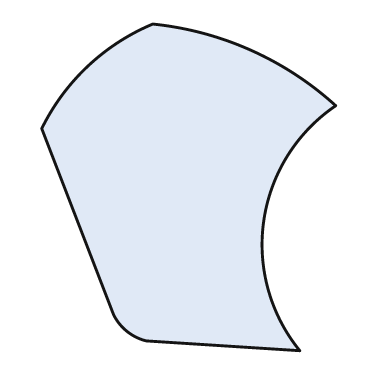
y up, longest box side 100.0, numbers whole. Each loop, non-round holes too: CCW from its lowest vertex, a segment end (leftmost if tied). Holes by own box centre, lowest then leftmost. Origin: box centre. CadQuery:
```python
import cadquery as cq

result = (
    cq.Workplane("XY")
    .moveTo(34.0, -50.0)
    .threePointArc((23.0, -10.0), (45.0, 25.0))
    .threePointArc((19.0, 42.0), (-11.0, 50.0))
    .threePointArc((-31.0, 37.0), (-45.0, 18.0))
    .lineTo(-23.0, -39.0)
    .threePointArc((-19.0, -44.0), (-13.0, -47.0))
    .close()
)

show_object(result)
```